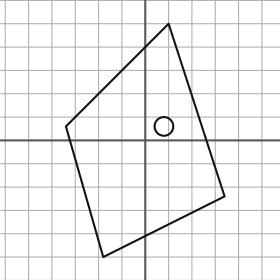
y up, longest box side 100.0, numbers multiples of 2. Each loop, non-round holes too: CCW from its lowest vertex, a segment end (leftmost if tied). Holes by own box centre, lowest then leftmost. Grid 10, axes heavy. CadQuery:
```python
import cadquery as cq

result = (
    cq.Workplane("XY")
    .moveTo(-18.0, -50.0)
    .lineTo(34.0, -24.0)
    .lineTo(10.0, 50.0)
    .lineTo(-34.0, 6.0)
    .close()
    .moveTo(8.0, 6.0)
    .circle(4.0)
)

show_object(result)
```